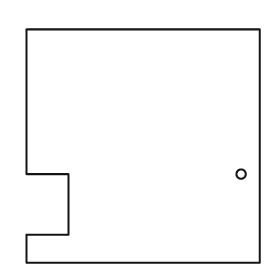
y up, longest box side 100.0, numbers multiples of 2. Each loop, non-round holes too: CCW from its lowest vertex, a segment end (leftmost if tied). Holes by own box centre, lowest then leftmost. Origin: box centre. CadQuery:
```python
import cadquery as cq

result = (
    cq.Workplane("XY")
    .moveTo(-50.0, -50.0)
    .lineTo(50.0, -50.0)
    .lineTo(50.0, 50.0)
    .lineTo(-50.0, 50.0)
    .lineTo(-50.0, -12.0)
    .lineTo(-32.0, -12.0)
    .lineTo(-32.0, -38.0)
    .lineTo(-50.0, -38.0)
    .close()
    .moveTo(42.0, -12.0)
    .circle(2.0)
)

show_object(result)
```